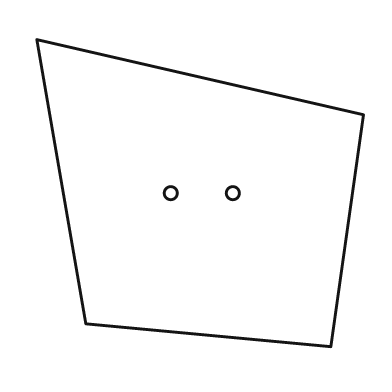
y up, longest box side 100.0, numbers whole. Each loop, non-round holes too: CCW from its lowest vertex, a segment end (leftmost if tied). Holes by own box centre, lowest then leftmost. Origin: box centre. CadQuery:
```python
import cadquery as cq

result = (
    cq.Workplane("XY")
    .moveTo(40.0, -47.0)
    .lineTo(50.0, 24.0)
    .lineTo(-50.0, 47.0)
    .lineTo(-35.0, -40.0)
    .close()
    .moveTo(-9.0, 0.0)
    .circle(2.0)
    .moveTo(10.0, 0.0)
    .circle(2.0)
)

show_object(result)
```